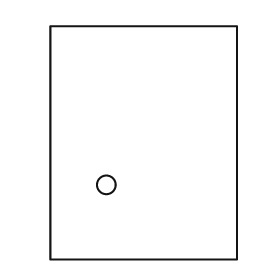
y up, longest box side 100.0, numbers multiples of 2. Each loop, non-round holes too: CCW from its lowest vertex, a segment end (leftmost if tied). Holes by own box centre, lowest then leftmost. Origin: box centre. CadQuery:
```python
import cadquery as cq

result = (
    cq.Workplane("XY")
    .moveTo(-40.0, -50.0)
    .lineTo(40.0, -50.0)
    .lineTo(40.0, 50.0)
    .lineTo(-40.0, 50.0)
    .close()
    .moveTo(-16.0, -18.0)
    .circle(4.0)
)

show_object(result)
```